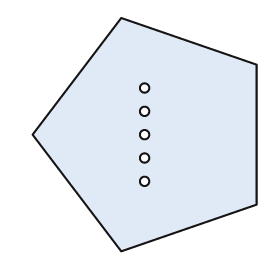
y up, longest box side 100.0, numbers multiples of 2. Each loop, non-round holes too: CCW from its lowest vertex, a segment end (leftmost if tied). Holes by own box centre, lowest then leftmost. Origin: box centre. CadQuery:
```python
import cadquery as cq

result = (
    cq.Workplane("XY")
    .moveTo(-10.0, -50.0)
    .lineTo(48.0, -30.0)
    .lineTo(48.0, 30.0)
    .lineTo(-10.0, 50.0)
    .lineTo(-48.0, 0.0)
    .close()
    .moveTo(0.0, -20.0)
    .circle(2.0)
    .moveTo(0.0, -10.0)
    .circle(2.0)
    .moveTo(0.0, 0.0)
    .circle(2.0)
    .moveTo(0.0, 10.0)
    .circle(2.0)
    .moveTo(0.0, 20.0)
    .circle(2.0)
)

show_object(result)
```